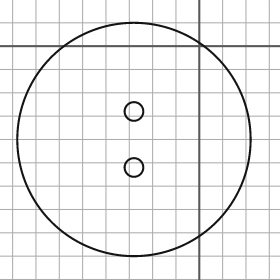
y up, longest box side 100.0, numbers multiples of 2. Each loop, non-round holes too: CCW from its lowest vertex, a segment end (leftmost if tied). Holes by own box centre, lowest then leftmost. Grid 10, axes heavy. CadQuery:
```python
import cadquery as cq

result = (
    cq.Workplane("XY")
    .moveTo(-28.0, -40.0)
    .circle(50.0)
    .moveTo(-28.0, -52.0)
    .circle(4.0)
    .moveTo(-28.0, -28.0)
    .circle(4.0)
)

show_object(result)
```